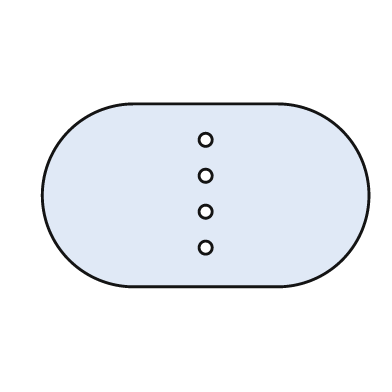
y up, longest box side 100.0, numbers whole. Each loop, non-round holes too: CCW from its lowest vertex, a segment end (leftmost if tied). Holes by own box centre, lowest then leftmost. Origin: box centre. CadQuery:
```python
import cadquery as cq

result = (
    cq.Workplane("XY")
    .moveTo(-22.0, -28.0)
    .lineTo(22.0, -28.0)
    .threePointArc((50.0, 0.0), (22.0, 28.0))
    .lineTo(-22.0, 28.0)
    .threePointArc((-50.0, 0.0), (-22.0, -28.0))
    .close()
    .moveTo(0.0, -16.0)
    .circle(2.0)
    .moveTo(0.0, -5.0)
    .circle(2.0)
    .moveTo(0.0, 6.0)
    .circle(2.0)
    .moveTo(0.0, 17.0)
    .circle(2.0)
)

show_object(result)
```